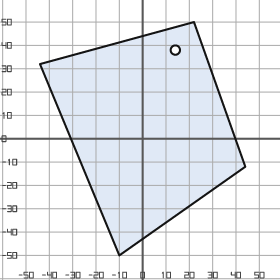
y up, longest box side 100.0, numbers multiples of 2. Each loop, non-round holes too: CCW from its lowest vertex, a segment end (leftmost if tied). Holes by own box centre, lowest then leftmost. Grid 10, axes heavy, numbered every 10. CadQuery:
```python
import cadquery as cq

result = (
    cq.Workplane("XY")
    .moveTo(-10.0, -50.0)
    .lineTo(44.0, -12.0)
    .lineTo(22.0, 50.0)
    .lineTo(-44.0, 32.0)
    .close()
    .moveTo(14.0, 38.0)
    .circle(2.0)
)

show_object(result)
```